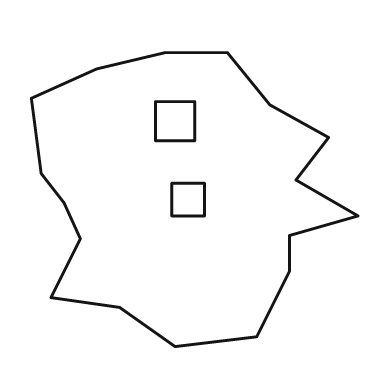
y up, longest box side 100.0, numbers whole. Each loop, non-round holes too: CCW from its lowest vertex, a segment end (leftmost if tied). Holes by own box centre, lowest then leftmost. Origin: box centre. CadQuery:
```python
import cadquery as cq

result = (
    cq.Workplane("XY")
    .moveTo(-6.0, -45.0)
    .lineTo(19.0, -42.0)
    .lineTo(29.0, -22.0)
    .lineTo(29.0, -11.0)
    .lineTo(50.0, -5.0)
    .lineTo(31.0, 6.0)
    .lineTo(41.0, 19.0)
    .lineTo(23.0, 29.0)
    .lineTo(10.0, 45.0)
    .lineTo(-9.0, 45.0)
    .lineTo(-30.0, 40.0)
    .lineTo(-50.0, 31.0)
    .lineTo(-47.0, 8.0)
    .lineTo(-40.0, -1.0)
    .lineTo(-35.0, -12.0)
    .lineTo(-44.0, -30.0)
    .lineTo(-23.0, -33.0)
    .close()
    .moveTo(-7.0, -5.0)
    .lineTo(3.0, -5.0)
    .lineTo(3.0, 5.0)
    .lineTo(-7.0, 5.0)
    .close()
    .moveTo(-12.0, 18.0)
    .lineTo(0.0, 18.0)
    .lineTo(0.0, 30.0)
    .lineTo(-12.0, 30.0)
    .close()
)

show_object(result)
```